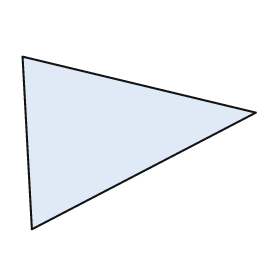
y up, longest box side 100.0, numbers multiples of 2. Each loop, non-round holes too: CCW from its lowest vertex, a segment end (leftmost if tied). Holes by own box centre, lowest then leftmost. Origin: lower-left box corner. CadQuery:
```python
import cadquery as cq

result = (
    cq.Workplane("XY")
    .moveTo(4.0, 0.0)
    .lineTo(100.0, 50.0)
    .lineTo(0.0, 74.0)
    .close()
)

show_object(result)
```